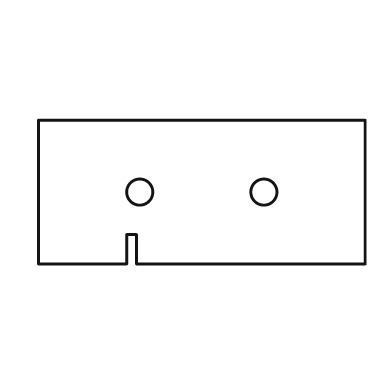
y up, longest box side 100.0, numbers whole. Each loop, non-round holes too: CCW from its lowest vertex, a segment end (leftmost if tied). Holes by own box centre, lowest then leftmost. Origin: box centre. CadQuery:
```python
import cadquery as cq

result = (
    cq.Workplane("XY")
    .moveTo(-50.0, -22.0)
    .lineTo(-23.0, -22.0)
    .lineTo(-23.0, -13.0)
    .lineTo(-20.0, -13.0)
    .lineTo(-20.0, -22.0)
    .lineTo(50.0, -22.0)
    .lineTo(50.0, 22.0)
    .lineTo(-50.0, 22.0)
    .close()
    .moveTo(-19.0, 0.0)
    .circle(4.0)
    .moveTo(19.0, 0.0)
    .circle(4.0)
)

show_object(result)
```